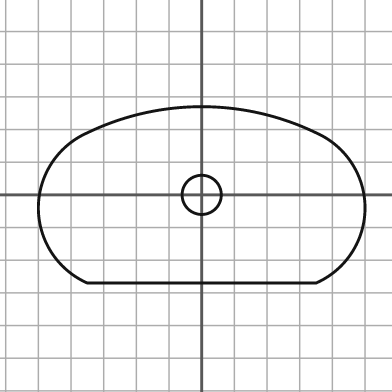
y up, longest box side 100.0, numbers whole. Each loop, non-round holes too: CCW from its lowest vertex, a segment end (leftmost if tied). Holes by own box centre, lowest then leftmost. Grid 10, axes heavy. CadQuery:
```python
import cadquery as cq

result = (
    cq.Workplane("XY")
    .moveTo(-35.0, -27.0)
    .lineTo(35.0, -27.0)
    .threePointArc((50.0, -4.0), (35.0, 19.0))
    .threePointArc((0.0, 27.0), (-35.0, 19.0))
    .threePointArc((-50.0, -4.0), (-35.0, -27.0))
    .close()
    .moveTo(0.0, 0.0)
    .circle(6.0)
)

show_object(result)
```